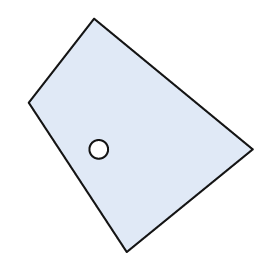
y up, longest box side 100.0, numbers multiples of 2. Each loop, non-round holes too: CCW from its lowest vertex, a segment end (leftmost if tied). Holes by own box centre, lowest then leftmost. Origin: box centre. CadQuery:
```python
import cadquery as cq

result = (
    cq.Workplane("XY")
    .moveTo(-6.0, -50.0)
    .lineTo(48.0, -6.0)
    .lineTo(-20.0, 50.0)
    .lineTo(-48.0, 14.0)
    .close()
    .moveTo(-18.0, -6.0)
    .circle(4.0)
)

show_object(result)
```